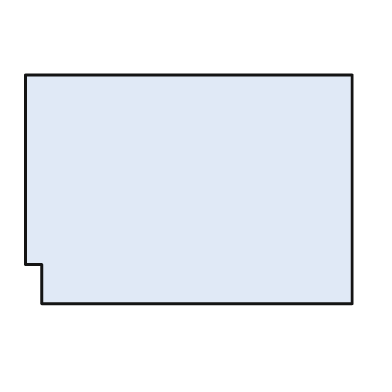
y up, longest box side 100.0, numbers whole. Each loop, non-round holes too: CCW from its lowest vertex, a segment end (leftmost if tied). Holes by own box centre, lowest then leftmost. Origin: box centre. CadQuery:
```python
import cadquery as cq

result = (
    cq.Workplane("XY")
    .moveTo(-45.0, -35.0)
    .lineTo(50.0, -35.0)
    .lineTo(50.0, 35.0)
    .lineTo(-50.0, 35.0)
    .lineTo(-50.0, -23.0)
    .lineTo(-45.0, -23.0)
    .close()
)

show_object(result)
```